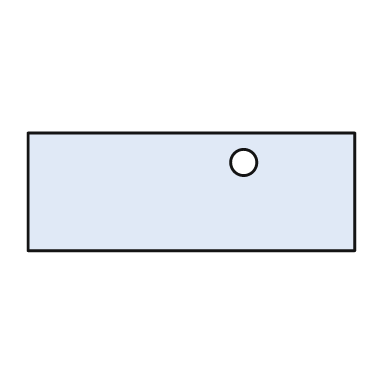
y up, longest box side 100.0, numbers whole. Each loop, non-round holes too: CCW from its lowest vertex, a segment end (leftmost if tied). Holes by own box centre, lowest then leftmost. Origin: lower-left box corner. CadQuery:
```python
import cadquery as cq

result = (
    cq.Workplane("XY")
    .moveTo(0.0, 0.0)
    .lineTo(100.0, 0.0)
    .lineTo(100.0, 36.0)
    .lineTo(0.0, 36.0)
    .close()
    .moveTo(66.0, 27.0)
    .circle(4.0)
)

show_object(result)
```